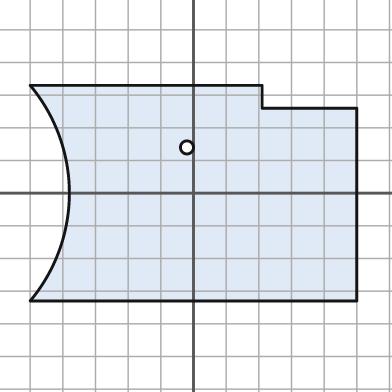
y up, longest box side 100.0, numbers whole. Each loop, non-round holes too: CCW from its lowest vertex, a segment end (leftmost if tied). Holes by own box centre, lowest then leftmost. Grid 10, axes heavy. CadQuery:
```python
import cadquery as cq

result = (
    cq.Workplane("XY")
    .moveTo(-50.0, -33.0)
    .lineTo(50.0, -33.0)
    .lineTo(50.0, 26.0)
    .lineTo(21.0, 26.0)
    .lineTo(21.0, 33.0)
    .lineTo(-50.0, 33.0)
    .threePointArc((-38.0, 0.0), (-50.0, -33.0))
    .close()
    .moveTo(-2.0, 14.0)
    .circle(2.0)
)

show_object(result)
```